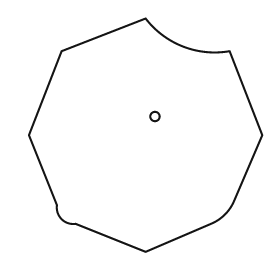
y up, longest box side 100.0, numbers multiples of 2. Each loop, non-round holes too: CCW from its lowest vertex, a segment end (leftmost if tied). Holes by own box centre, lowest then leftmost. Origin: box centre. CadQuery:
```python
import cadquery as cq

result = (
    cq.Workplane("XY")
    .moveTo(0.0, -50.0)
    .lineTo(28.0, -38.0)
    .threePointArc((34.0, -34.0), (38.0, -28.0))
    .lineTo(50.0, 0.0)
    .lineTo(36.0, 36.0)
    .threePointArc((16.0, 38.0), (0.0, 50.0))
    .lineTo(-36.0, 36.0)
    .lineTo(-50.0, 0.0)
    .lineTo(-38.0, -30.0)
    .threePointArc((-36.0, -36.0), (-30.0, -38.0))
    .close()
    .moveTo(4.0, 8.0)
    .circle(2.0)
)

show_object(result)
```